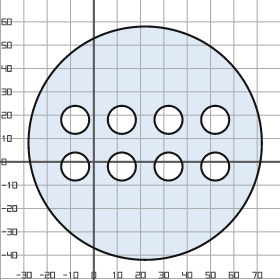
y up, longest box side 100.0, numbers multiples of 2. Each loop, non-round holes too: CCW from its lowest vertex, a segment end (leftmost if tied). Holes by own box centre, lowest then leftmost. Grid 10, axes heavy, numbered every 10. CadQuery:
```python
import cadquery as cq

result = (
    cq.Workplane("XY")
    .moveTo(22.0, 8.0)
    .circle(50.0)
    .moveTo(-8.0, -2.0)
    .circle(6.0)
    .moveTo(12.0, -2.0)
    .circle(6.0)
    .moveTo(32.0, -2.0)
    .circle(6.0)
    .moveTo(52.0, -2.0)
    .circle(6.0)
    .moveTo(-8.0, 18.0)
    .circle(6.0)
    .moveTo(12.0, 18.0)
    .circle(6.0)
    .moveTo(32.0, 18.0)
    .circle(6.0)
    .moveTo(52.0, 18.0)
    .circle(6.0)
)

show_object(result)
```